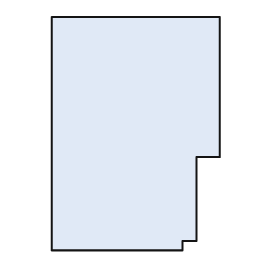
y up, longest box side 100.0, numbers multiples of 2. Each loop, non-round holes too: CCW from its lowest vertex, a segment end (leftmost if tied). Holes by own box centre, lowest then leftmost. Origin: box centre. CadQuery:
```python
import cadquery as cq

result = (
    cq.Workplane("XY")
    .moveTo(-36.0, -50.0)
    .lineTo(20.0, -50.0)
    .lineTo(20.0, -46.0)
    .lineTo(26.0, -46.0)
    .lineTo(26.0, -10.0)
    .lineTo(36.0, -10.0)
    .lineTo(36.0, 50.0)
    .lineTo(-36.0, 50.0)
    .close()
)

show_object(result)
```